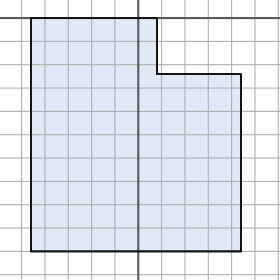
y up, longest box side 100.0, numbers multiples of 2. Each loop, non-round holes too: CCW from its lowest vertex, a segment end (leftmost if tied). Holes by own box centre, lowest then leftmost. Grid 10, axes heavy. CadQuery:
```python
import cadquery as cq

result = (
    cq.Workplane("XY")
    .moveTo(-46.0, -100.0)
    .lineTo(44.0, -100.0)
    .lineTo(44.0, -24.0)
    .lineTo(8.0, -24.0)
    .lineTo(8.0, 0.0)
    .lineTo(-46.0, 0.0)
    .close()
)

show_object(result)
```